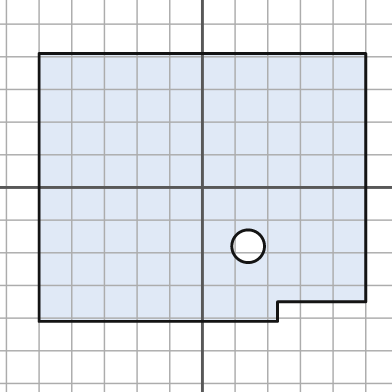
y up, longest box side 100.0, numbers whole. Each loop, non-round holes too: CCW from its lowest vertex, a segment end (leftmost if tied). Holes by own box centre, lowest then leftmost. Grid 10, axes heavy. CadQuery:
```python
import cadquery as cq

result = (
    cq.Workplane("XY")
    .moveTo(-50.0, -41.0)
    .lineTo(23.0, -41.0)
    .lineTo(23.0, -35.0)
    .lineTo(50.0, -35.0)
    .lineTo(50.0, 41.0)
    .lineTo(-50.0, 41.0)
    .close()
    .moveTo(14.0, -18.0)
    .circle(5.0)
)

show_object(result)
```